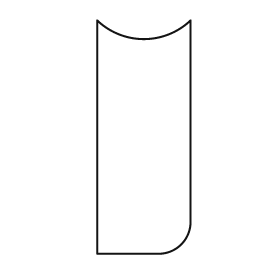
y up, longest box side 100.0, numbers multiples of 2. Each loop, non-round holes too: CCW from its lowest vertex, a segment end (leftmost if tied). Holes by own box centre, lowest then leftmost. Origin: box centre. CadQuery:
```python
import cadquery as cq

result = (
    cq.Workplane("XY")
    .moveTo(-20.0, -50.0)
    .lineTo(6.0, -50.0)
    .threePointArc((16.0, -46.0), (20.0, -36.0))
    .lineTo(20.0, 50.0)
    .threePointArc((0.0, 42.0), (-20.0, 50.0))
    .close()
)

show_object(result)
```